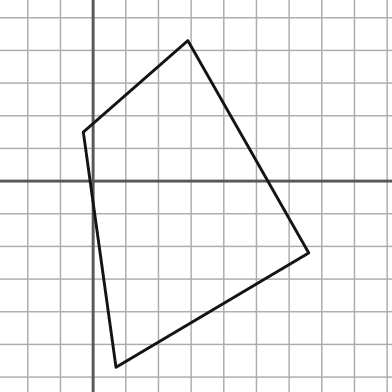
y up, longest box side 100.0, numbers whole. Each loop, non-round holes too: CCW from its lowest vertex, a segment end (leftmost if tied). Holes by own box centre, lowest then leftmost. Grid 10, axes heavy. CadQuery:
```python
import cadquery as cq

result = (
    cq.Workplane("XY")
    .moveTo(7.0, -57.0)
    .lineTo(66.0, -22.0)
    .lineTo(29.0, 43.0)
    .lineTo(-3.0, 15.0)
    .close()
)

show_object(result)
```